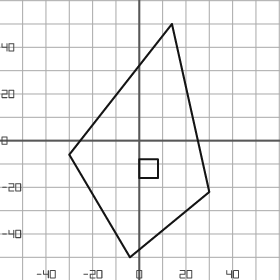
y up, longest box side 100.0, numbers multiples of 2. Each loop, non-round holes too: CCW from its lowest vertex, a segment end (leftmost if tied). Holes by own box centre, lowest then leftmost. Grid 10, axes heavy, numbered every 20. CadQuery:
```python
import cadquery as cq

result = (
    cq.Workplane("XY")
    .moveTo(-4.0, -50.0)
    .lineTo(30.0, -22.0)
    .lineTo(14.0, 50.0)
    .lineTo(-30.0, -6.0)
    .close()
    .moveTo(0.0, -16.0)
    .lineTo(8.0, -16.0)
    .lineTo(8.0, -8.0)
    .lineTo(0.0, -8.0)
    .close()
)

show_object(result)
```